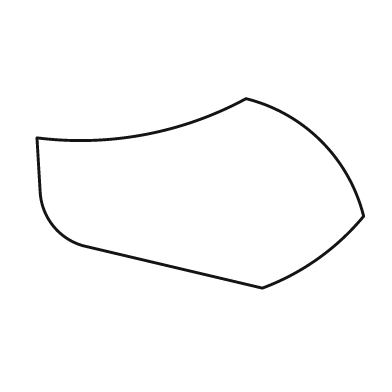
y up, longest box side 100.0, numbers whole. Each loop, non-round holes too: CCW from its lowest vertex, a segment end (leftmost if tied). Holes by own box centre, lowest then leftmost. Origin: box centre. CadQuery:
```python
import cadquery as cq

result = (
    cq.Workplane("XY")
    .moveTo(19.0, -29.0)
    .threePointArc((36.0, -20.0), (50.0, -7.0))
    .threePointArc((37.0, 16.0), (14.0, 29.0))
    .threePointArc((-17.0, 18.0), (-50.0, 17.0))
    .lineTo(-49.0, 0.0)
    .threePointArc((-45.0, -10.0), (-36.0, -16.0))
    .close()
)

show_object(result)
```